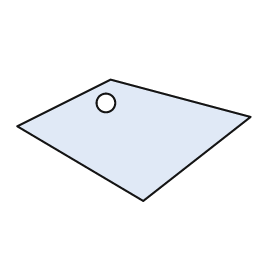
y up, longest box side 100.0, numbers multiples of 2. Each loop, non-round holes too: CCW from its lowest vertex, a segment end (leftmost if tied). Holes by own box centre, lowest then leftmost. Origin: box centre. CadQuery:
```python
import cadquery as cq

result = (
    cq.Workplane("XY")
    .moveTo(4.0, -26.0)
    .lineTo(50.0, 10.0)
    .lineTo(-10.0, 26.0)
    .lineTo(-50.0, 6.0)
    .close()
    .moveTo(-12.0, 16.0)
    .circle(4.0)
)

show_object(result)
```